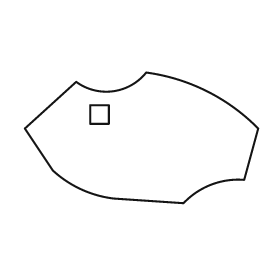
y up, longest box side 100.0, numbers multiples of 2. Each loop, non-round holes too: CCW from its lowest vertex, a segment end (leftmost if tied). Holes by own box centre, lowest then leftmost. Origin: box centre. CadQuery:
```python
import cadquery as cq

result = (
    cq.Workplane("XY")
    .moveTo(18.0, -28.0)
    .threePointArc((30.0, -20.0), (44.0, -18.0))
    .lineTo(50.0, 4.0)
    .threePointArc((28.0, 20.0), (2.0, 28.0))
    .threePointArc((-12.0, 20.0), (-28.0, 24.0))
    .lineTo(-50.0, 4.0)
    .lineTo(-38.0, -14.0)
    .threePointArc((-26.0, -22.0), (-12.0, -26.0))
    .close()
    .moveTo(-22.0, 6.0)
    .lineTo(-14.0, 6.0)
    .lineTo(-14.0, 14.0)
    .lineTo(-22.0, 14.0)
    .close()
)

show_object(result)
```